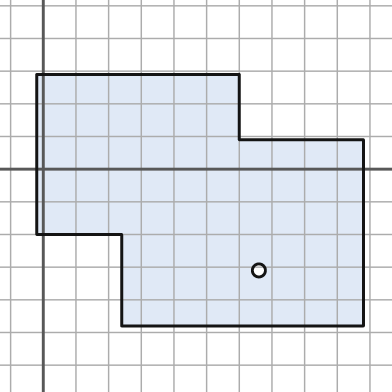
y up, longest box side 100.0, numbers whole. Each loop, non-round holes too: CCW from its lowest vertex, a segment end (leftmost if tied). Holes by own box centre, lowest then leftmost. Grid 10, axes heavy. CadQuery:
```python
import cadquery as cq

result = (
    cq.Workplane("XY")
    .moveTo(24.0, -48.0)
    .lineTo(98.0, -48.0)
    .lineTo(98.0, 9.0)
    .lineTo(60.0, 9.0)
    .lineTo(60.0, 29.0)
    .lineTo(-2.0, 29.0)
    .lineTo(-2.0, -20.0)
    .lineTo(24.0, -20.0)
    .close()
    .moveTo(66.0, -31.0)
    .circle(2.0)
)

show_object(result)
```